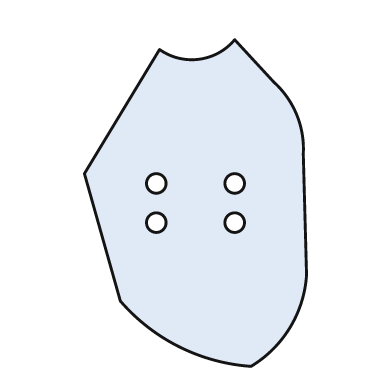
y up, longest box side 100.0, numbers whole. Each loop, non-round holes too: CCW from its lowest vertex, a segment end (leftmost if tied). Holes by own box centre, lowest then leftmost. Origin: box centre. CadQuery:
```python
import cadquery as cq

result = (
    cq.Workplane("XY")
    .moveTo(17.0, -50.0)
    .threePointArc((29.0, -38.0), (34.0, -22.0))
    .lineTo(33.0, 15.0)
    .threePointArc((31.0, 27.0), (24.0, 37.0))
    .lineTo(12.0, 50.0)
    .threePointArc((1.0, 44.0), (-11.0, 47.0))
    .lineTo(-34.0, 9.0)
    .lineTo(-23.0, -30.0)
    .threePointArc((-5.0, -44.0), (17.0, -50.0))
    .close()
    .moveTo(-12.0, -6.0)
    .circle(3.0)
    .moveTo(12.0, -6.0)
    .circle(3.0)
    .moveTo(-12.0, 6.0)
    .circle(3.0)
    .moveTo(12.0, 6.0)
    .circle(3.0)
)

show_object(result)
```